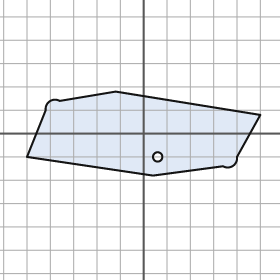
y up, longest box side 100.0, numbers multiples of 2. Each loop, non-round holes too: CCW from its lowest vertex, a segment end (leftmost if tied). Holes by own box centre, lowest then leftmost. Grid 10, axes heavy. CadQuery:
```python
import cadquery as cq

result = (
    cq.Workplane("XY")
    .moveTo(4.0, -18.0)
    .lineTo(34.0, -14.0)
    .threePointArc((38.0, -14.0), (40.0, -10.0))
    .lineTo(50.0, 8.0)
    .lineTo(-12.0, 18.0)
    .lineTo(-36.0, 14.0)
    .threePointArc((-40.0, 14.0), (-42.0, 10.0))
    .lineTo(-50.0, -10.0)
    .close()
    .moveTo(6.0, -10.0)
    .circle(2.0)
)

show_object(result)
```